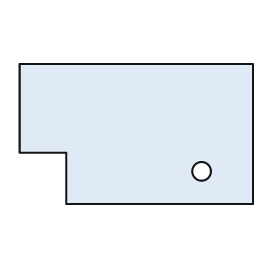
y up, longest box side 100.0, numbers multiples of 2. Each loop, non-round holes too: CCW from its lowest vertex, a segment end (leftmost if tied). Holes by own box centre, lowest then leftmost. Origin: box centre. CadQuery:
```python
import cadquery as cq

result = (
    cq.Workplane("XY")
    .moveTo(-30.0, -30.0)
    .lineTo(50.0, -30.0)
    .lineTo(50.0, 30.0)
    .lineTo(-50.0, 30.0)
    .lineTo(-50.0, -8.0)
    .lineTo(-30.0, -8.0)
    .close()
    .moveTo(28.0, -16.0)
    .circle(4.0)
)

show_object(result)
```